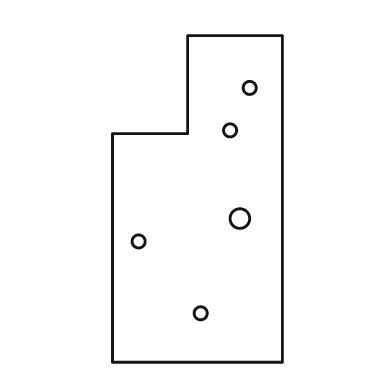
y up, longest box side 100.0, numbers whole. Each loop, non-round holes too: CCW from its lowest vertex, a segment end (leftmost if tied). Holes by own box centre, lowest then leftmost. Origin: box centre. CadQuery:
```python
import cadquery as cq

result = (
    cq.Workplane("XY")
    .moveTo(-26.0, -50.0)
    .lineTo(26.0, -50.0)
    .lineTo(26.0, 50.0)
    .lineTo(-3.0, 50.0)
    .lineTo(-3.0, 20.0)
    .lineTo(-26.0, 20.0)
    .close()
    .moveTo(1.0, -35.0)
    .circle(2.0)
    .moveTo(-18.0, -13.0)
    .circle(2.0)
    .moveTo(13.0, -6.0)
    .circle(3.0)
    .moveTo(10.0, 21.0)
    .circle(2.0)
    .moveTo(16.0, 34.0)
    .circle(2.0)
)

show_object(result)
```